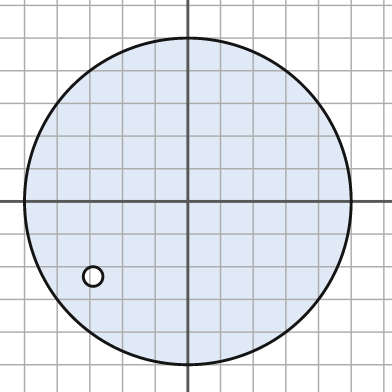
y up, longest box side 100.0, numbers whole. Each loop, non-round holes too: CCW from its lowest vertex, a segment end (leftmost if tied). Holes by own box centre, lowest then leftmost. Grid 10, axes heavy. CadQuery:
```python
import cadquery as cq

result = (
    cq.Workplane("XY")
    .moveTo(0.0, 0.0)
    .circle(50.0)
    .moveTo(-29.0, -23.0)
    .circle(3.0)
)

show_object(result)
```